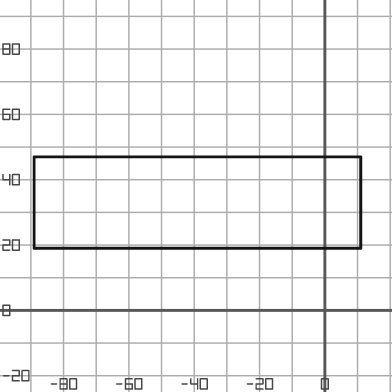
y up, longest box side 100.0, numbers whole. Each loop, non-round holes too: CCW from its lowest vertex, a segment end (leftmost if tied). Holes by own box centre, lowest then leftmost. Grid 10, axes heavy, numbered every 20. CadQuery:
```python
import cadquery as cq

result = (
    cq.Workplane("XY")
    .moveTo(-89.0, 19.0)
    .lineTo(11.0, 19.0)
    .lineTo(11.0, 47.0)
    .lineTo(-89.0, 47.0)
    .close()
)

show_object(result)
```